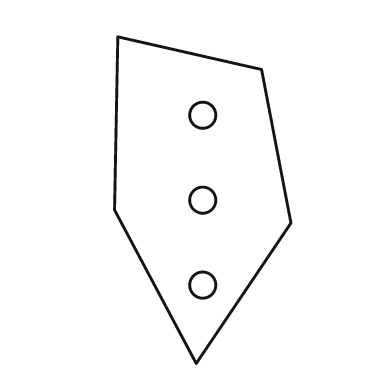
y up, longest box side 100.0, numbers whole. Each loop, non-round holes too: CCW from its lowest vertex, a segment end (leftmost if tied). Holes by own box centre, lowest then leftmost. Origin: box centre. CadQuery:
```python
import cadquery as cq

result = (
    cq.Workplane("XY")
    .moveTo(-2.0, -50.0)
    .lineTo(27.0, -7.0)
    .lineTo(18.0, 40.0)
    .lineTo(-26.0, 50.0)
    .lineTo(-27.0, -3.0)
    .close()
    .moveTo(0.0, -26.0)
    .circle(4.0)
    .moveTo(0.0, 0.0)
    .circle(4.0)
    .moveTo(0.0, 26.0)
    .circle(4.0)
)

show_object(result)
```